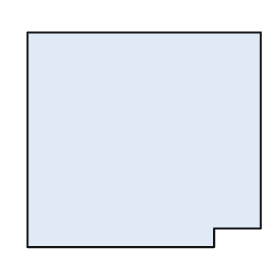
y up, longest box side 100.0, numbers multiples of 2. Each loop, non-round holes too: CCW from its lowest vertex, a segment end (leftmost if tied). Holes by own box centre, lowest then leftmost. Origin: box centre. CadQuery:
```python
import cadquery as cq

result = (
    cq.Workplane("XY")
    .moveTo(-50.0, -46.0)
    .lineTo(30.0, -46.0)
    .lineTo(30.0, -38.0)
    .lineTo(50.0, -38.0)
    .lineTo(50.0, 46.0)
    .lineTo(-50.0, 46.0)
    .close()
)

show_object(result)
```